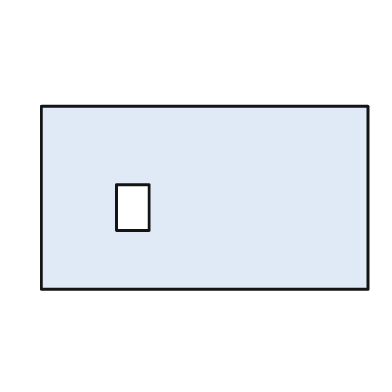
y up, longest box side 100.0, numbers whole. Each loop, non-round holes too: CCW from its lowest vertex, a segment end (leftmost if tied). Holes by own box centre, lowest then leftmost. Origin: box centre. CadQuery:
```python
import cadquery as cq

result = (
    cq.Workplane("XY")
    .moveTo(-50.0, -28.0)
    .lineTo(50.0, -28.0)
    .lineTo(50.0, 28.0)
    .lineTo(-50.0, 28.0)
    .close()
    .moveTo(-27.0, -10.0)
    .lineTo(-17.0, -10.0)
    .lineTo(-17.0, 4.0)
    .lineTo(-27.0, 4.0)
    .close()
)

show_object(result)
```